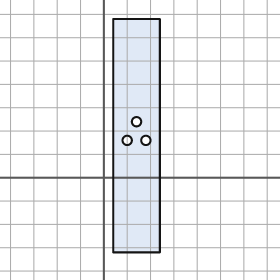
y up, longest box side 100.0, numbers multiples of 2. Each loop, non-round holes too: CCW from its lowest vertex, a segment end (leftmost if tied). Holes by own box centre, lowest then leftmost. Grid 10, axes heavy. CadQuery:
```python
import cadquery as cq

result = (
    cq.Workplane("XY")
    .moveTo(4.0, -32.0)
    .lineTo(24.0, -32.0)
    .lineTo(24.0, 68.0)
    .lineTo(4.0, 68.0)
    .close()
    .moveTo(10.0, 16.0)
    .circle(2.0)
    .moveTo(18.0, 16.0)
    .circle(2.0)
    .moveTo(14.0, 24.0)
    .circle(2.0)
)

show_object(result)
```